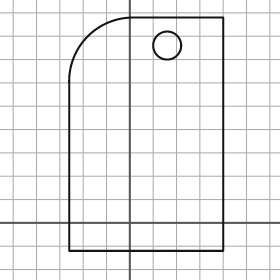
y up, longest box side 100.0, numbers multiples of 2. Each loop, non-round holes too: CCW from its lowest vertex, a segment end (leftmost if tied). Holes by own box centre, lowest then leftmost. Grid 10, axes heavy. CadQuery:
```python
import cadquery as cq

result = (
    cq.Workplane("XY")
    .moveTo(-26.0, -12.0)
    .lineTo(40.0, -12.0)
    .lineTo(40.0, 88.0)
    .lineTo(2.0, 88.0)
    .threePointArc((-18.0, 80.0), (-26.0, 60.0))
    .close()
    .moveTo(16.0, 76.0)
    .circle(6.0)
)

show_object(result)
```